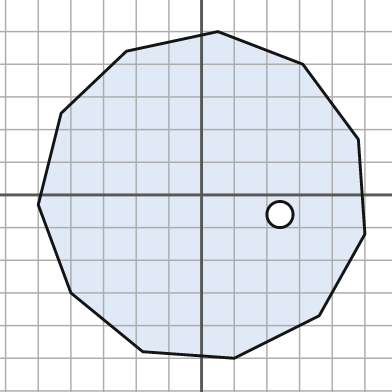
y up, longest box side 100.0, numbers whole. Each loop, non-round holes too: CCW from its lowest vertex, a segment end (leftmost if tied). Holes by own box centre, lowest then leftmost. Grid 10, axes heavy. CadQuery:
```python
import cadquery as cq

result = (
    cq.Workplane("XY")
    .moveTo(10.0, -50.0)
    .lineTo(36.0, -37.0)
    .lineTo(50.0, -12.0)
    .lineTo(48.0, 17.0)
    .lineTo(31.0, 40.0)
    .lineTo(5.0, 50.0)
    .lineTo(-23.0, 44.0)
    .lineTo(-43.0, 25.0)
    .lineTo(-50.0, -3.0)
    .lineTo(-40.0, -30.0)
    .lineTo(-18.0, -48.0)
    .close()
    .moveTo(24.0, -6.0)
    .circle(4.0)
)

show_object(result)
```